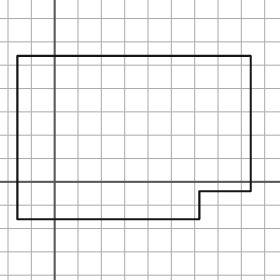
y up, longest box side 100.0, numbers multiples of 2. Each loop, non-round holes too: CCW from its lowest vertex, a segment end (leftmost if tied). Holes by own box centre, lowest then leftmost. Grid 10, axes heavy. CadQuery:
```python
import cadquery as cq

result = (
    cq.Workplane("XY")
    .moveTo(-16.0, -16.0)
    .lineTo(62.0, -16.0)
    .lineTo(62.0, -4.0)
    .lineTo(84.0, -4.0)
    .lineTo(84.0, 54.0)
    .lineTo(-16.0, 54.0)
    .close()
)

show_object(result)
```